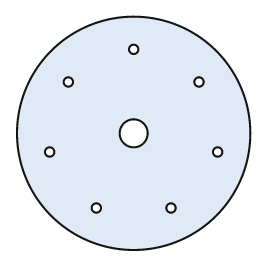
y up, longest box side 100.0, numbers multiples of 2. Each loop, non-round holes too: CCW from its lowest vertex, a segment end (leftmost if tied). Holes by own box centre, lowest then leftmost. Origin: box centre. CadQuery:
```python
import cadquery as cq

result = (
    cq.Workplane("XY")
    .moveTo(0.0, 0.0)
    .circle(50.0)
    .moveTo(-16.0, -32.0)
    .circle(2.0)
    .moveTo(16.0, -32.0)
    .circle(2.0)
    .moveTo(-36.0, -8.0)
    .circle(2.0)
    .moveTo(36.0, -8.0)
    .circle(2.0)
    .moveTo(0.0, 0.0)
    .circle(6.0)
    .moveTo(-28.0, 22.0)
    .circle(2.0)
    .moveTo(28.0, 22.0)
    .circle(2.0)
    .moveTo(0.0, 36.0)
    .circle(2.0)
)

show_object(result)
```